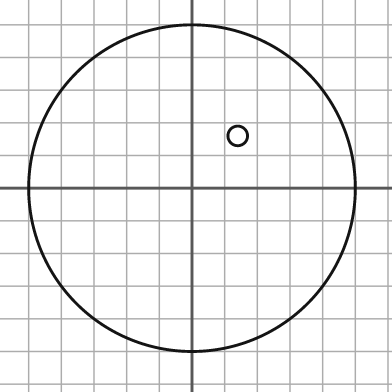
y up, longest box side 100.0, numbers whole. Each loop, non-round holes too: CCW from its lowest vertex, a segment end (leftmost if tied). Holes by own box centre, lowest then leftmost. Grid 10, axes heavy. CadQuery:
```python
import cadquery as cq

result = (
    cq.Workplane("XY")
    .moveTo(0.0, 0.0)
    .circle(50.0)
    .moveTo(14.0, 16.0)
    .circle(3.0)
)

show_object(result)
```